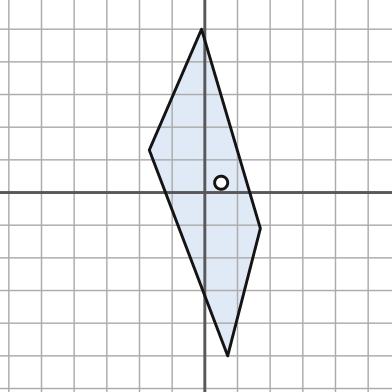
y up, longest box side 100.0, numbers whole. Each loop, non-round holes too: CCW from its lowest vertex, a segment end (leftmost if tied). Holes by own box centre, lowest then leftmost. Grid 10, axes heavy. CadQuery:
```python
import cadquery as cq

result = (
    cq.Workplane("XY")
    .moveTo(7.0, -50.0)
    .lineTo(17.0, -11.0)
    .lineTo(-1.0, 50.0)
    .lineTo(-17.0, 13.0)
    .close()
    .moveTo(5.0, 3.0)
    .circle(2.0)
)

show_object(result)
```